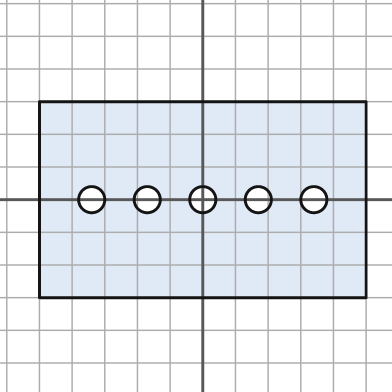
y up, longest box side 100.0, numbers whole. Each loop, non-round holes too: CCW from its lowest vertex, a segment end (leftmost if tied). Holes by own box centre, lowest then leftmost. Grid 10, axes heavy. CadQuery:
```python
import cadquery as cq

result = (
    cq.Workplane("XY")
    .moveTo(-50.0, -30.0)
    .lineTo(50.0, -30.0)
    .lineTo(50.0, 30.0)
    .lineTo(-50.0, 30.0)
    .close()
    .moveTo(-34.0, 0.0)
    .circle(4.0)
    .moveTo(-17.0, 0.0)
    .circle(4.0)
    .moveTo(0.0, 0.0)
    .circle(4.0)
    .moveTo(17.0, 0.0)
    .circle(4.0)
    .moveTo(34.0, 0.0)
    .circle(4.0)
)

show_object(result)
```